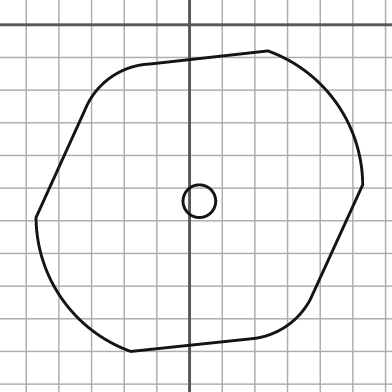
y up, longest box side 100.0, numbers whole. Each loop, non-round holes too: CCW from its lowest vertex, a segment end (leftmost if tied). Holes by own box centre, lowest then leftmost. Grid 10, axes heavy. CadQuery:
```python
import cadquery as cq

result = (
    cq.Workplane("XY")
    .moveTo(-18.0, -100.0)
    .lineTo(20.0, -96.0)
    .threePointArc((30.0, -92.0), (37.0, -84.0))
    .lineTo(53.0, -49.0)
    .threePointArc((45.0, -24.0), (24.0, -8.0))
    .lineTo(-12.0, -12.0)
    .threePointArc((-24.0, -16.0), (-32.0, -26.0))
    .lineTo(-47.0, -59.0)
    .threePointArc((-39.0, -84.0), (-18.0, -100.0))
    .close()
    .moveTo(3.0, -54.0)
    .circle(5.0)
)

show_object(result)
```